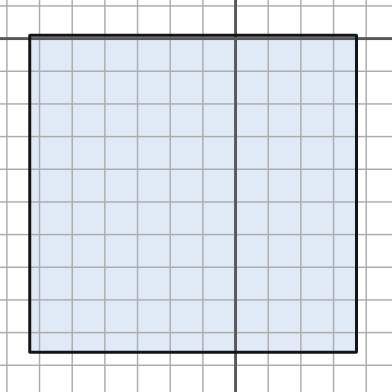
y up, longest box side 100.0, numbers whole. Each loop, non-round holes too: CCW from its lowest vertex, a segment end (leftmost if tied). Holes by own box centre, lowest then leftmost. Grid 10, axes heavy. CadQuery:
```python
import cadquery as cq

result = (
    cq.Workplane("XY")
    .moveTo(-63.0, -96.0)
    .lineTo(37.0, -96.0)
    .lineTo(37.0, 1.0)
    .lineTo(-63.0, 1.0)
    .close()
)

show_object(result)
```